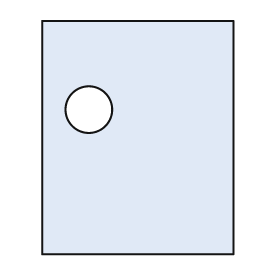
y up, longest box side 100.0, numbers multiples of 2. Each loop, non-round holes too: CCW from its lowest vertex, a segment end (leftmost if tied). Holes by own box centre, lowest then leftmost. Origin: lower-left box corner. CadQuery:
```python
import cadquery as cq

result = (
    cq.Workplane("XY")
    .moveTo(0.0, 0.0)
    .lineTo(82.0, 0.0)
    .lineTo(82.0, 100.0)
    .lineTo(0.0, 100.0)
    .close()
    .moveTo(20.0, 62.0)
    .circle(10.0)
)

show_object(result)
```